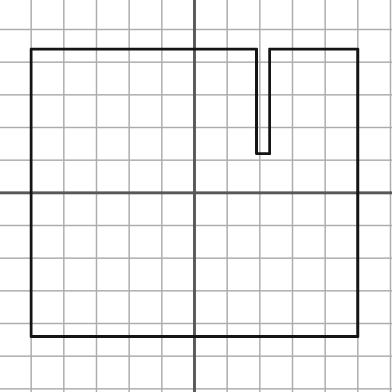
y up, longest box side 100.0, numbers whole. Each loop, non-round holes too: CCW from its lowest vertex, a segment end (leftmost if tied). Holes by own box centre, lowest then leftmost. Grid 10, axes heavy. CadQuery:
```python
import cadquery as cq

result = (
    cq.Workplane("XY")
    .moveTo(-50.0, -44.0)
    .lineTo(50.0, -44.0)
    .lineTo(50.0, 44.0)
    .lineTo(23.0, 44.0)
    .lineTo(23.0, 12.0)
    .lineTo(19.0, 12.0)
    .lineTo(19.0, 44.0)
    .lineTo(-50.0, 44.0)
    .close()
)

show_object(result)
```